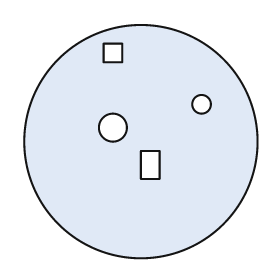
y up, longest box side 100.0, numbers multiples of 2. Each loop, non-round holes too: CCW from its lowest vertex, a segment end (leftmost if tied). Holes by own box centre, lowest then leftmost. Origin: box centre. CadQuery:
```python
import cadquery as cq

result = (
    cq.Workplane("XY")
    .moveTo(0.0, 0.0)
    .circle(50.0)
    .moveTo(0.0, -16.0)
    .lineTo(8.0, -16.0)
    .lineTo(8.0, -4.0)
    .lineTo(0.0, -4.0)
    .close()
    .moveTo(-12.0, 6.0)
    .circle(6.0)
    .moveTo(26.0, 16.0)
    .circle(4.0)
    .moveTo(-16.0, 34.0)
    .lineTo(-8.0, 34.0)
    .lineTo(-8.0, 42.0)
    .lineTo(-16.0, 42.0)
    .close()
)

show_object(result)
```